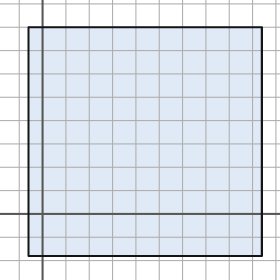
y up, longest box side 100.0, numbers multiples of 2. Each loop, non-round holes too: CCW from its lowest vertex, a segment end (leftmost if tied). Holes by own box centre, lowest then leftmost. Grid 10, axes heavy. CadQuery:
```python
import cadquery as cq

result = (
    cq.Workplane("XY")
    .moveTo(-6.0, -18.0)
    .lineTo(94.0, -18.0)
    .lineTo(94.0, 80.0)
    .lineTo(-6.0, 80.0)
    .close()
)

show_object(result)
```